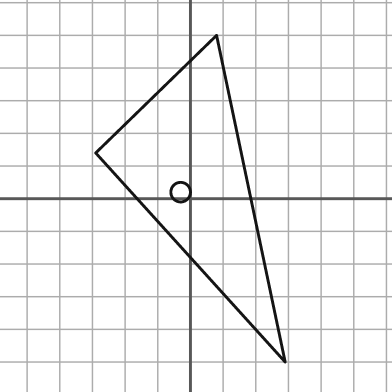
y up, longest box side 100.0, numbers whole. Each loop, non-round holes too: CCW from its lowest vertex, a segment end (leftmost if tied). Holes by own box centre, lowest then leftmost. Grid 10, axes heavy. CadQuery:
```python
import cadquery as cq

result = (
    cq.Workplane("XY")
    .moveTo(29.0, -50.0)
    .lineTo(8.0, 50.0)
    .lineTo(-29.0, 14.0)
    .close()
    .moveTo(-3.0, 2.0)
    .circle(3.0)
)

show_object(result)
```